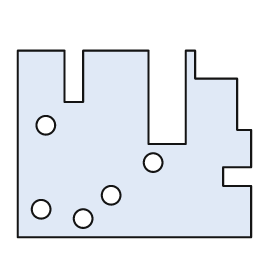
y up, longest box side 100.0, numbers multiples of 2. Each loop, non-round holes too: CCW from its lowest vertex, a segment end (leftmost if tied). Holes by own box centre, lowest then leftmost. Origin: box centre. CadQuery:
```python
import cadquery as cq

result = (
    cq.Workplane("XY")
    .moveTo(-50.0, -40.0)
    .lineTo(50.0, -40.0)
    .lineTo(50.0, -18.0)
    .lineTo(38.0, -18.0)
    .lineTo(38.0, -10.0)
    .lineTo(50.0, -10.0)
    .lineTo(50.0, 6.0)
    .lineTo(44.0, 6.0)
    .lineTo(44.0, 28.0)
    .lineTo(26.0, 28.0)
    .lineTo(26.0, 40.0)
    .lineTo(22.0, 40.0)
    .lineTo(22.0, 0.0)
    .lineTo(6.0, 0.0)
    .lineTo(6.0, 40.0)
    .lineTo(-22.0, 40.0)
    .lineTo(-22.0, 18.0)
    .lineTo(-30.0, 18.0)
    .lineTo(-30.0, 40.0)
    .lineTo(-50.0, 40.0)
    .close()
    .moveTo(-22.0, -32.0)
    .circle(4.0)
    .moveTo(-40.0, -28.0)
    .circle(4.0)
    .moveTo(-10.0, -22.0)
    .circle(4.0)
    .moveTo(8.0, -8.0)
    .circle(4.0)
    .moveTo(-38.0, 8.0)
    .circle(4.0)
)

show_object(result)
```